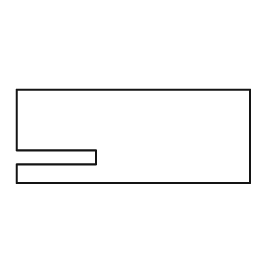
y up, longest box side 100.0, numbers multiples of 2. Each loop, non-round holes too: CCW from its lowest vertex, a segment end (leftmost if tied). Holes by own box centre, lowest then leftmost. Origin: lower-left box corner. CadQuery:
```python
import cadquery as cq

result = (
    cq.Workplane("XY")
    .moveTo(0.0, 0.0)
    .lineTo(100.0, 0.0)
    .lineTo(100.0, 40.0)
    .lineTo(0.0, 40.0)
    .lineTo(0.0, 14.0)
    .lineTo(34.0, 14.0)
    .lineTo(34.0, 8.0)
    .lineTo(0.0, 8.0)
    .close()
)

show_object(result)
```